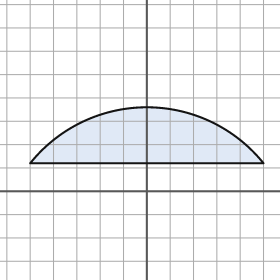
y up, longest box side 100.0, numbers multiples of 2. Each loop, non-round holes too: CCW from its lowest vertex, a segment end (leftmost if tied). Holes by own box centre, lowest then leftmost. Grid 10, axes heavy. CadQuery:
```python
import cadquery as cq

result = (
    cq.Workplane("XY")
    .moveTo(-50.0, 12.0)
    .lineTo(50.0, 12.0)
    .threePointArc((0.0, 36.0), (-50.0, 12.0))
    .close()
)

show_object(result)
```